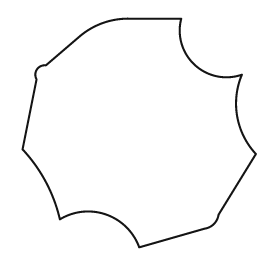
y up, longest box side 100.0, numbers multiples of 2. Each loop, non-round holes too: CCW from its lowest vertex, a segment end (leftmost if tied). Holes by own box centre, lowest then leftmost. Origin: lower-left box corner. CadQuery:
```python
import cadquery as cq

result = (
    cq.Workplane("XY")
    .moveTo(50.0, 0.0)
    .lineTo(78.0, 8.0)
    .threePointArc((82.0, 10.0), (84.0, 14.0))
    .lineTo(100.0, 40.0)
    .threePointArc((92.0, 56.0), (94.0, 74.0))
    .threePointArc((74.0, 78.0), (68.0, 98.0))
    .lineTo(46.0, 98.0)
    .threePointArc((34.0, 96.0), (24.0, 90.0))
    .lineTo(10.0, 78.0)
    .threePointArc((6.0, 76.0), (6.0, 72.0))
    .lineTo(0.0, 42.0)
    .threePointArc((10.0, 28.0), (16.0, 12.0))
    .threePointArc((36.0, 14.0), (50.0, 0.0))
    .close()
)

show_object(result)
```